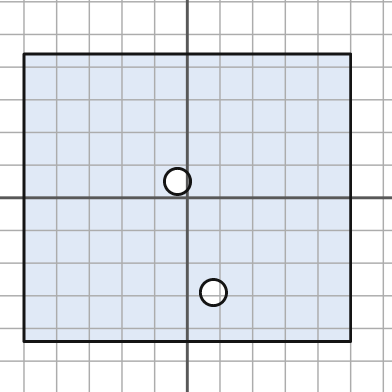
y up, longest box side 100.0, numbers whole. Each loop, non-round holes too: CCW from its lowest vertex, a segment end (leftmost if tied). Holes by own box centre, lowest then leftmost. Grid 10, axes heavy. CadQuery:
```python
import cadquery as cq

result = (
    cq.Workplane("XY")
    .moveTo(-50.0, -44.0)
    .lineTo(50.0, -44.0)
    .lineTo(50.0, 44.0)
    .lineTo(-50.0, 44.0)
    .close()
    .moveTo(8.0, -29.0)
    .circle(4.0)
    .moveTo(-3.0, 5.0)
    .circle(4.0)
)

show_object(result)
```